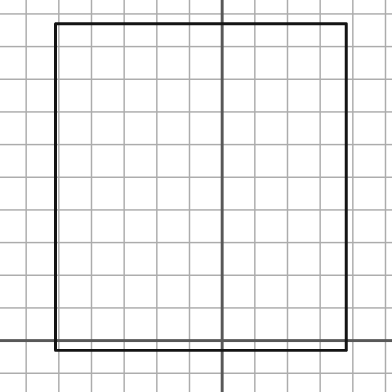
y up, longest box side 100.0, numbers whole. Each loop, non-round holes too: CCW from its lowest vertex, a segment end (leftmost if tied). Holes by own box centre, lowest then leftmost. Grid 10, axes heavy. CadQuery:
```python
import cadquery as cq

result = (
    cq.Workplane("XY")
    .moveTo(-51.0, -3.0)
    .lineTo(38.0, -3.0)
    .lineTo(38.0, 97.0)
    .lineTo(-51.0, 97.0)
    .close()
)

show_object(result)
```